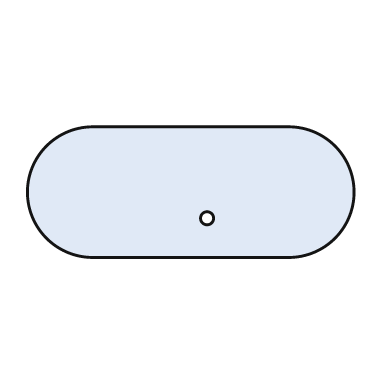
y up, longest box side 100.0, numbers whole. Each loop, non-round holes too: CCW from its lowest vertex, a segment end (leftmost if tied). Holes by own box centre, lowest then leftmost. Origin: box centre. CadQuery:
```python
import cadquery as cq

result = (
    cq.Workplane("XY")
    .moveTo(-30.0, -20.0)
    .lineTo(30.0, -20.0)
    .threePointArc((50.0, 0.0), (30.0, 20.0))
    .lineTo(-30.0, 20.0)
    .threePointArc((-50.0, 0.0), (-30.0, -20.0))
    .close()
    .moveTo(5.0, -8.0)
    .circle(2.0)
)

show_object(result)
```